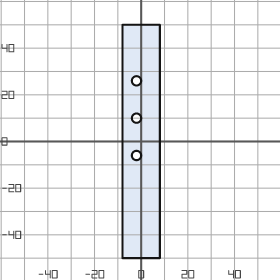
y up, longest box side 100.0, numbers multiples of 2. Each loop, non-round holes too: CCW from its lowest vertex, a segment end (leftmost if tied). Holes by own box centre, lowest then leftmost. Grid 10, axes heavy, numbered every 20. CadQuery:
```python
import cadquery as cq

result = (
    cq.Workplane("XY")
    .moveTo(-8.0, -50.0)
    .lineTo(8.0, -50.0)
    .lineTo(8.0, 50.0)
    .lineTo(-8.0, 50.0)
    .close()
    .moveTo(-2.0, -6.0)
    .circle(2.0)
    .moveTo(-2.0, 10.0)
    .circle(2.0)
    .moveTo(-2.0, 26.0)
    .circle(2.0)
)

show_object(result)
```